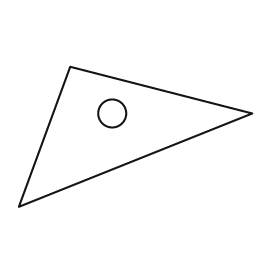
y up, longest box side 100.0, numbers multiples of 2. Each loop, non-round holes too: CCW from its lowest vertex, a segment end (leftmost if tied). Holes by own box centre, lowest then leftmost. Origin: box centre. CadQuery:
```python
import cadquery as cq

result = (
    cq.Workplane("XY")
    .moveTo(-50.0, -30.0)
    .lineTo(50.0, 10.0)
    .lineTo(-28.0, 30.0)
    .close()
    .moveTo(-10.0, 10.0)
    .circle(6.0)
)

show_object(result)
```